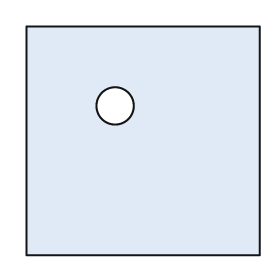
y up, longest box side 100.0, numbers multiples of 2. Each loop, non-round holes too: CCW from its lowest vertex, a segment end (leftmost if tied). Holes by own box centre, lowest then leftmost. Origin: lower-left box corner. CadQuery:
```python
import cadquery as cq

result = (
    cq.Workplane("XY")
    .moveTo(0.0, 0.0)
    .lineTo(100.0, 0.0)
    .lineTo(100.0, 98.0)
    .lineTo(0.0, 98.0)
    .close()
    .moveTo(38.0, 64.0)
    .circle(8.0)
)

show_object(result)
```